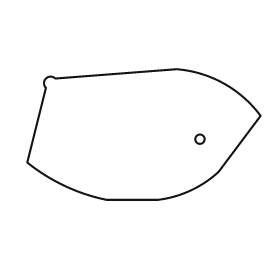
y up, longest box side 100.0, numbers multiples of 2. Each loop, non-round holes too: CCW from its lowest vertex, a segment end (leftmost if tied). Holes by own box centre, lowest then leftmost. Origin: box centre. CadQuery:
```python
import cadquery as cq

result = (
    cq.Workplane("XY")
    .moveTo(-16.0, -28.0)
    .lineTo(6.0, -28.0)
    .threePointArc((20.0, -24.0), (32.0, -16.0))
    .lineTo(50.0, 8.0)
    .threePointArc((34.0, 22.0), (14.0, 28.0))
    .lineTo(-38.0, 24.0)
    .threePointArc((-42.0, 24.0), (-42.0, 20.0))
    .lineTo(-50.0, -12.0)
    .threePointArc((-34.0, -22.0), (-16.0, -28.0))
    .close()
    .moveTo(24.0, -2.0)
    .circle(2.0)
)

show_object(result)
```